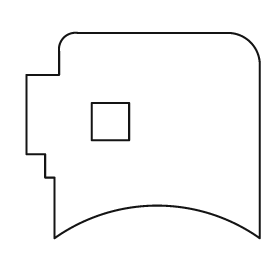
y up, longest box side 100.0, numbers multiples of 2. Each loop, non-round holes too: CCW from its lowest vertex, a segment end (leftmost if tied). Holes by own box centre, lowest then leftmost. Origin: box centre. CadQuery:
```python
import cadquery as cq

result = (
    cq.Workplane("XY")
    .moveTo(-38.0, -44.0)
    .threePointArc((6.0, -30.0), (50.0, -44.0))
    .lineTo(50.0, 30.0)
    .threePointArc((46.0, 40.0), (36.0, 44.0))
    .lineTo(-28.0, 44.0)
    .threePointArc((-34.0, 42.0), (-36.0, 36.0))
    .lineTo(-36.0, 26.0)
    .lineTo(-50.0, 26.0)
    .lineTo(-50.0, -8.0)
    .lineTo(-42.0, -8.0)
    .lineTo(-42.0, -18.0)
    .lineTo(-38.0, -18.0)
    .close()
    .moveTo(-22.0, -2.0)
    .lineTo(-6.0, -2.0)
    .lineTo(-6.0, 14.0)
    .lineTo(-22.0, 14.0)
    .close()
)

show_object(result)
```